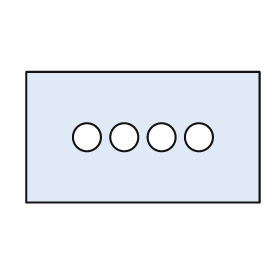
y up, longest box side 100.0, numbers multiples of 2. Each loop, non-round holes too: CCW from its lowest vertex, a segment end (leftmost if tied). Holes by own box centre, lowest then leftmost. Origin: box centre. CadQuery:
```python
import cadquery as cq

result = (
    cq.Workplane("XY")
    .moveTo(-50.0, -28.0)
    .lineTo(50.0, -28.0)
    .lineTo(50.0, 28.0)
    .lineTo(-50.0, 28.0)
    .close()
    .moveTo(-24.0, 0.0)
    .circle(6.0)
    .moveTo(-8.0, 0.0)
    .circle(6.0)
    .moveTo(8.0, 0.0)
    .circle(6.0)
    .moveTo(24.0, 0.0)
    .circle(6.0)
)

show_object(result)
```